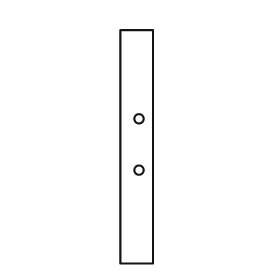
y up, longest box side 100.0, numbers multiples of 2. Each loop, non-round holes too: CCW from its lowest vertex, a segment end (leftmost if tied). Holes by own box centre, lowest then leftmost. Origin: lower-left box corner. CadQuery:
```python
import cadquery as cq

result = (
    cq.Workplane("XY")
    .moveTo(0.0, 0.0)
    .lineTo(14.0, 0.0)
    .lineTo(14.0, 100.0)
    .lineTo(0.0, 100.0)
    .close()
    .moveTo(8.0, 40.0)
    .circle(2.0)
    .moveTo(8.0, 62.0)
    .circle(2.0)
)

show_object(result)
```